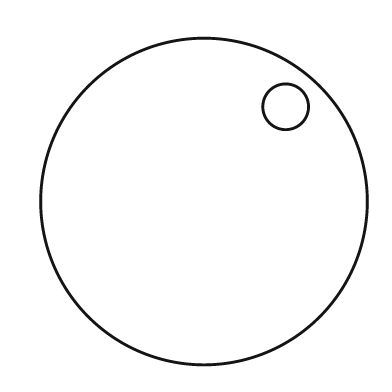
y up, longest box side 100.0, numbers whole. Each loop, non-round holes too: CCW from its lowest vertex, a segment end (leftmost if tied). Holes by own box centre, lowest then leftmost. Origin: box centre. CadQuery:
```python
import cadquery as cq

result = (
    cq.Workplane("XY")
    .moveTo(0.0, 0.0)
    .circle(50.0)
    .moveTo(25.0, 29.0)
    .circle(7.0)
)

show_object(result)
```